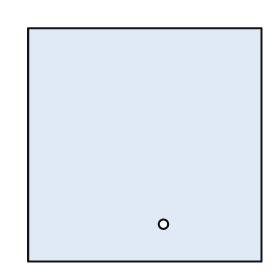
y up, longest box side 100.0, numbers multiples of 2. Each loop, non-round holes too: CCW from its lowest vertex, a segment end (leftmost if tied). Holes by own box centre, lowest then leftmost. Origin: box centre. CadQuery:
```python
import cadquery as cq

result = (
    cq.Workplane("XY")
    .moveTo(-50.0, -50.0)
    .lineTo(50.0, -50.0)
    .lineTo(50.0, 50.0)
    .lineTo(-50.0, 50.0)
    .close()
    .moveTo(8.0, -34.0)
    .circle(2.0)
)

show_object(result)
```